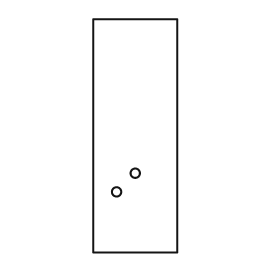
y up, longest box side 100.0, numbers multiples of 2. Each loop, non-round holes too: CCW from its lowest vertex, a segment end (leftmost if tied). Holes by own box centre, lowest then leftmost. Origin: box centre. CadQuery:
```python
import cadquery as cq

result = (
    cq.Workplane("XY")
    .moveTo(-18.0, -50.0)
    .lineTo(18.0, -50.0)
    .lineTo(18.0, 50.0)
    .lineTo(-18.0, 50.0)
    .close()
    .moveTo(-8.0, -24.0)
    .circle(2.0)
    .moveTo(0.0, -16.0)
    .circle(2.0)
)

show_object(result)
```